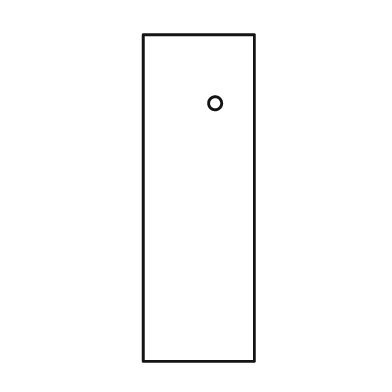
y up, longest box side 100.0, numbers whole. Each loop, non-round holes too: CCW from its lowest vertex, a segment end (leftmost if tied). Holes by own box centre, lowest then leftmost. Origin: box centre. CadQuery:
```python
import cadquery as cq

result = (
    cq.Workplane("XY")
    .moveTo(-17.0, -50.0)
    .lineTo(17.0, -50.0)
    .lineTo(17.0, 50.0)
    .lineTo(-17.0, 50.0)
    .close()
    .moveTo(5.0, 29.0)
    .circle(2.0)
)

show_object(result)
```